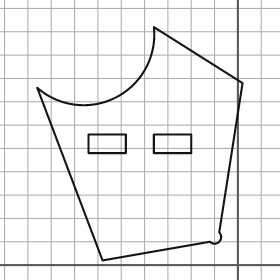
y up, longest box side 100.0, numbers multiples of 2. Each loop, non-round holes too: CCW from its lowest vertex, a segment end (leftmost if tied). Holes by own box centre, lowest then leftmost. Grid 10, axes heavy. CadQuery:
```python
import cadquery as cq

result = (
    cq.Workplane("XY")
    .moveTo(-58.0, 2.0)
    .lineTo(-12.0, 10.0)
    .threePointArc((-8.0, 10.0), (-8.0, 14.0))
    .lineTo(2.0, 78.0)
    .lineTo(-36.0, 102.0)
    .threePointArc((-52.0, 72.0), (-86.0, 76.0))
    .close()
    .moveTo(-64.0, 48.0)
    .lineTo(-48.0, 48.0)
    .lineTo(-48.0, 56.0)
    .lineTo(-64.0, 56.0)
    .close()
    .moveTo(-36.0, 48.0)
    .lineTo(-20.0, 48.0)
    .lineTo(-20.0, 56.0)
    .lineTo(-36.0, 56.0)
    .close()
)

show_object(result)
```